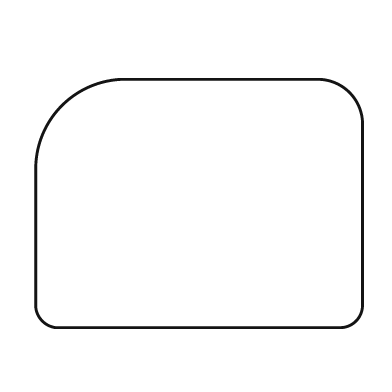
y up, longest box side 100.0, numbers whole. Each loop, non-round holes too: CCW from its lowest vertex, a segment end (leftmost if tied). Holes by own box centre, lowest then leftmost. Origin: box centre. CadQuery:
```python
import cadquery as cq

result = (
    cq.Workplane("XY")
    .moveTo(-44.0, -38.0)
    .lineTo(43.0, -38.0)
    .threePointArc((48.0, -36.0), (50.0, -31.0))
    .lineTo(50.0, 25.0)
    .threePointArc((46.0, 34.0), (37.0, 38.0))
    .lineTo(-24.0, 38.0)
    .threePointArc((-42.0, 30.0), (-50.0, 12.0))
    .lineTo(-50.0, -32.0)
    .threePointArc((-48.0, -36.0), (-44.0, -38.0))
    .close()
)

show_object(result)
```